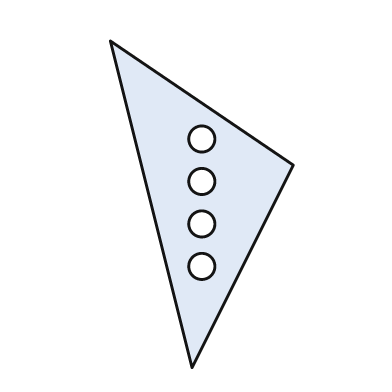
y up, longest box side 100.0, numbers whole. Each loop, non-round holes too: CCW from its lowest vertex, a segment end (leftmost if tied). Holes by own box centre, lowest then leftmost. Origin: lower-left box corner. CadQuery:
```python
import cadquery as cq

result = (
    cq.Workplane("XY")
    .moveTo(25.0, 0.0)
    .lineTo(56.0, 62.0)
    .lineTo(0.0, 100.0)
    .close()
    .moveTo(28.0, 31.0)
    .circle(4.0)
    .moveTo(28.0, 44.0)
    .circle(4.0)
    .moveTo(28.0, 57.0)
    .circle(4.0)
    .moveTo(28.0, 70.0)
    .circle(4.0)
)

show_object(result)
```